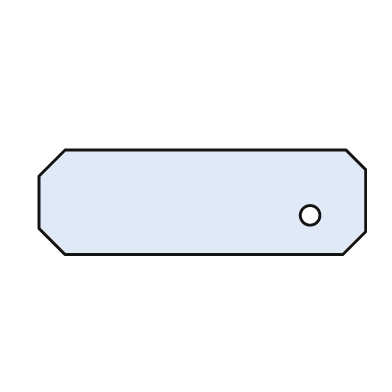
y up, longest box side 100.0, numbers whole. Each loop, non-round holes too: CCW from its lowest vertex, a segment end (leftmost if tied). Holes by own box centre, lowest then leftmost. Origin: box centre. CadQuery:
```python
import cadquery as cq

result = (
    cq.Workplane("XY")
    .moveTo(-42.0, -16.0)
    .lineTo(43.0, -16.0)
    .lineTo(50.0, -9.0)
    .lineTo(50.0, 10.0)
    .lineTo(44.0, 16.0)
    .lineTo(-42.0, 16.0)
    .lineTo(-50.0, 8.0)
    .lineTo(-50.0, -8.0)
    .close()
    .moveTo(33.0, -4.0)
    .circle(3.0)
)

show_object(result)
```